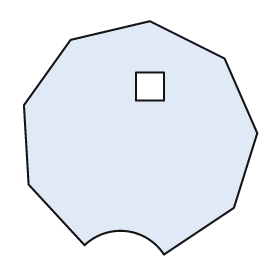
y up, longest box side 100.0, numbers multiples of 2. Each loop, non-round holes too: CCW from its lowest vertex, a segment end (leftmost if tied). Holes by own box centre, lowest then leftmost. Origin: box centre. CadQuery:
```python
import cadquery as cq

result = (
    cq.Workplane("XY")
    .moveTo(10.0, -50.0)
    .lineTo(40.0, -30.0)
    .lineTo(50.0, 2.0)
    .lineTo(36.0, 34.0)
    .lineTo(4.0, 50.0)
    .lineTo(-30.0, 42.0)
    .lineTo(-50.0, 14.0)
    .lineTo(-48.0, -20.0)
    .lineTo(-24.0, -46.0)
    .threePointArc((-6.0, -40.0), (10.0, -50.0))
    .close()
    .moveTo(-2.0, 16.0)
    .lineTo(10.0, 16.0)
    .lineTo(10.0, 28.0)
    .lineTo(-2.0, 28.0)
    .close()
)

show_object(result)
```